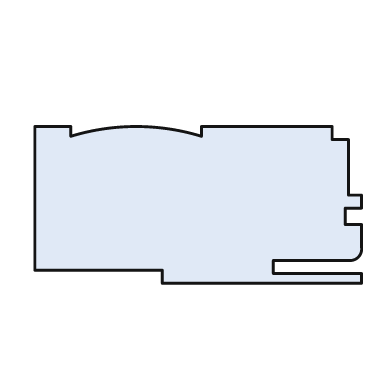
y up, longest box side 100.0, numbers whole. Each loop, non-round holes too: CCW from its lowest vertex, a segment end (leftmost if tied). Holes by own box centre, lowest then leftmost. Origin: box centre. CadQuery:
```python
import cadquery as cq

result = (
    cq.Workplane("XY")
    .moveTo(-11.0, -24.0)
    .lineTo(50.0, -24.0)
    .lineTo(50.0, -21.0)
    .lineTo(23.0, -21.0)
    .lineTo(23.0, -17.0)
    .lineTo(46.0, -17.0)
    .threePointArc((49.0, -16.0), (50.0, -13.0))
    .lineTo(50.0, -6.0)
    .lineTo(45.0, -6.0)
    .lineTo(45.0, -1.0)
    .lineTo(50.0, -1.0)
    .lineTo(50.0, 3.0)
    .lineTo(46.0, 3.0)
    .lineTo(46.0, 20.0)
    .lineTo(41.0, 20.0)
    .lineTo(41.0, 24.0)
    .lineTo(1.0, 24.0)
    .lineTo(1.0, 21.0)
    .threePointArc((-19.0, 24.0), (-39.0, 21.0))
    .lineTo(-39.0, 24.0)
    .lineTo(-50.0, 24.0)
    .lineTo(-50.0, -20.0)
    .lineTo(-11.0, -20.0)
    .close()
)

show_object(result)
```